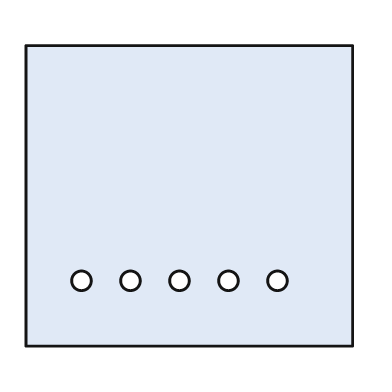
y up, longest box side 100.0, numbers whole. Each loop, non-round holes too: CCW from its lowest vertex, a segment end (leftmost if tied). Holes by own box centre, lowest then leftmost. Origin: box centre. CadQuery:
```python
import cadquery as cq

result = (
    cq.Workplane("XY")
    .moveTo(-50.0, -46.0)
    .lineTo(50.0, -46.0)
    .lineTo(50.0, 46.0)
    .lineTo(-50.0, 46.0)
    .close()
    .moveTo(-33.0, -26.0)
    .circle(3.0)
    .moveTo(-18.0, -26.0)
    .circle(3.0)
    .moveTo(-3.0, -26.0)
    .circle(3.0)
    .moveTo(12.0, -26.0)
    .circle(3.0)
    .moveTo(27.0, -26.0)
    .circle(3.0)
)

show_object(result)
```